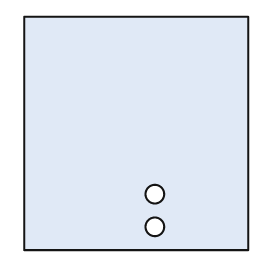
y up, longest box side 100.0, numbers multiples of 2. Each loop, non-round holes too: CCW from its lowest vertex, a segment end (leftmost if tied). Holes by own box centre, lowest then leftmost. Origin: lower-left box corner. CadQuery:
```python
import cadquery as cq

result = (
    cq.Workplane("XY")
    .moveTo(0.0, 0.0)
    .lineTo(96.0, 0.0)
    .lineTo(96.0, 100.0)
    .lineTo(0.0, 100.0)
    .close()
    .moveTo(56.0, 10.0)
    .circle(4.0)
    .moveTo(56.0, 24.0)
    .circle(4.0)
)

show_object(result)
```